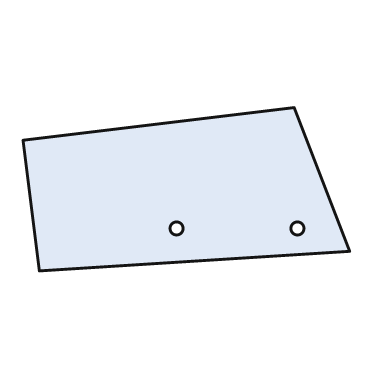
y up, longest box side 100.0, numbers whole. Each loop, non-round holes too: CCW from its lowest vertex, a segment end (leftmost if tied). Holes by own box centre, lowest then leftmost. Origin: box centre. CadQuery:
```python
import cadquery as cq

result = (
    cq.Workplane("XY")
    .moveTo(-45.0, -25.0)
    .lineTo(50.0, -19.0)
    .lineTo(33.0, 25.0)
    .lineTo(-50.0, 15.0)
    .close()
    .moveTo(-3.0, -12.0)
    .circle(2.0)
    .moveTo(34.0, -12.0)
    .circle(2.0)
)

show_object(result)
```